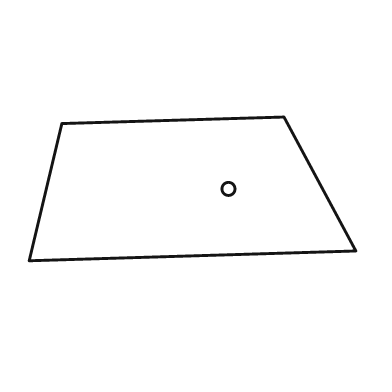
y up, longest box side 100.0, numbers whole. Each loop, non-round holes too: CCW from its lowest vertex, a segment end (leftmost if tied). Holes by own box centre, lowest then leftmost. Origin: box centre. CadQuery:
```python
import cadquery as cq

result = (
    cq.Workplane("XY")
    .moveTo(-50.0, -22.0)
    .lineTo(50.0, -19.0)
    .lineTo(28.0, 22.0)
    .lineTo(-40.0, 20.0)
    .close()
    .moveTo(11.0, 0.0)
    .circle(2.0)
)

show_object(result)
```